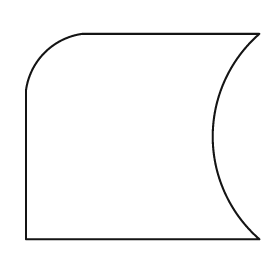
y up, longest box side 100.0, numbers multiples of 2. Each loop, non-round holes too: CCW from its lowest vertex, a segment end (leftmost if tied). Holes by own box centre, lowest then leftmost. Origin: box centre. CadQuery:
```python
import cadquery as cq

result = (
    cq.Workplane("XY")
    .moveTo(-50.0, -44.0)
    .lineTo(50.0, -44.0)
    .threePointArc((30.0, 0.0), (50.0, 44.0))
    .lineTo(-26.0, 44.0)
    .threePointArc((-42.0, 36.0), (-50.0, 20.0))
    .close()
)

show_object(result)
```